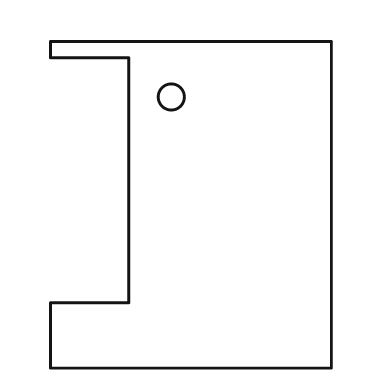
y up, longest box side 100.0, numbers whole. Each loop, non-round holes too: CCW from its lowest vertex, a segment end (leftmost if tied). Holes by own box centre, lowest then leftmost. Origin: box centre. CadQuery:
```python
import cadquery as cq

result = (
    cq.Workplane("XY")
    .moveTo(-43.0, -50.0)
    .lineTo(43.0, -50.0)
    .lineTo(43.0, 50.0)
    .lineTo(-43.0, 50.0)
    .lineTo(-43.0, 45.0)
    .lineTo(-19.0, 45.0)
    .lineTo(-19.0, -30.0)
    .lineTo(-43.0, -30.0)
    .close()
    .moveTo(-6.0, 33.0)
    .circle(4.0)
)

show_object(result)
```